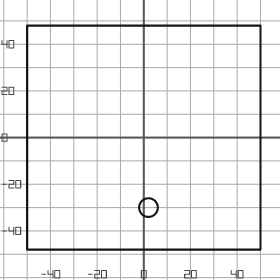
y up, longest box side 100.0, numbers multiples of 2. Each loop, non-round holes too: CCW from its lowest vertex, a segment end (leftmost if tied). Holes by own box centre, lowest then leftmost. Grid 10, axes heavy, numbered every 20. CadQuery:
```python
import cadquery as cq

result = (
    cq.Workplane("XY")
    .moveTo(-50.0, -48.0)
    .lineTo(50.0, -48.0)
    .lineTo(50.0, 48.0)
    .lineTo(-50.0, 48.0)
    .close()
    .moveTo(2.0, -30.0)
    .circle(4.0)
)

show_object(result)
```